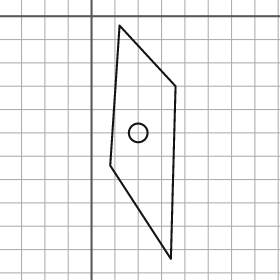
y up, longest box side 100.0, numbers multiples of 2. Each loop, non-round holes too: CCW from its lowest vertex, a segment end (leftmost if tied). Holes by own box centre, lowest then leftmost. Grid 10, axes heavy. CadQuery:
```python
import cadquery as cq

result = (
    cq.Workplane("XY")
    .moveTo(34.0, -104.0)
    .lineTo(36.0, -30.0)
    .lineTo(12.0, -4.0)
    .lineTo(8.0, -64.0)
    .close()
    .moveTo(20.0, -50.0)
    .circle(4.0)
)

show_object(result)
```